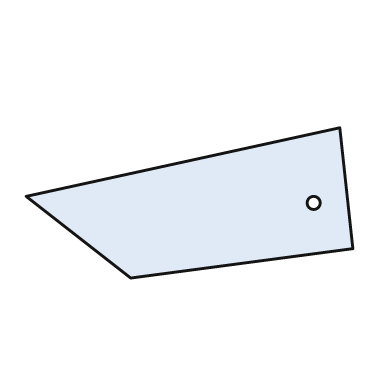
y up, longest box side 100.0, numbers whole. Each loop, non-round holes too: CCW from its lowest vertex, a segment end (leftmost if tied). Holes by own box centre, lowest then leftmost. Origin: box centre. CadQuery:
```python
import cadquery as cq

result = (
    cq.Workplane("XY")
    .moveTo(-18.0, -23.0)
    .lineTo(50.0, -14.0)
    .lineTo(46.0, 23.0)
    .lineTo(-50.0, 2.0)
    .close()
    .moveTo(38.0, 0.0)
    .circle(2.0)
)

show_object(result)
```